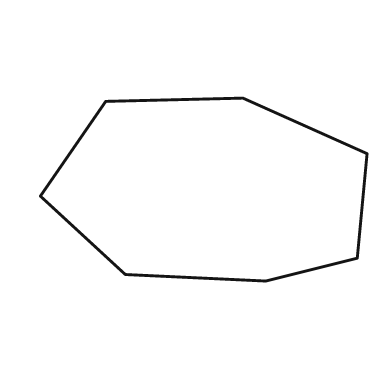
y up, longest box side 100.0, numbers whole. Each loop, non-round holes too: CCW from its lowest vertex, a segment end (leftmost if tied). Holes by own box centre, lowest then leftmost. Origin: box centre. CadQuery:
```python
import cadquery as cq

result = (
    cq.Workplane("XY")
    .moveTo(19.0, -28.0)
    .lineTo(47.0, -21.0)
    .lineTo(50.0, 11.0)
    .lineTo(12.0, 28.0)
    .lineTo(-30.0, 27.0)
    .lineTo(-50.0, -2.0)
    .lineTo(-24.0, -26.0)
    .close()
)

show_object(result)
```